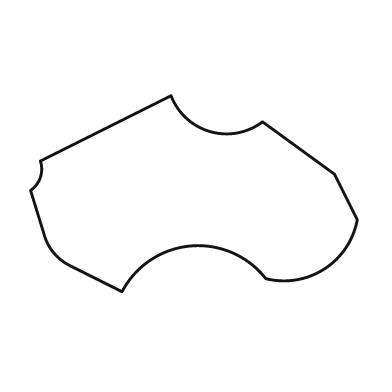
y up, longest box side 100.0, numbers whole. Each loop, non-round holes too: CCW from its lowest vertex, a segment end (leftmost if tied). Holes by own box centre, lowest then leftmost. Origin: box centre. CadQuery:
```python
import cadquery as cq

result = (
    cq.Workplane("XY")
    .moveTo(-22.0, -30.0)
    .threePointArc((-1.0, -16.0), (22.0, -26.0))
    .threePointArc((40.0, -23.0), (50.0, -8.0))
    .lineTo(43.0, 6.0)
    .lineTo(21.0, 22.0)
    .threePointArc((5.0, 19.0), (-7.0, 30.0))
    .lineTo(-47.0, 10.0)
    .threePointArc((-47.0, 5.0), (-50.0, 1.0))
    .lineTo(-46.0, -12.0)
    .threePointArc((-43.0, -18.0), (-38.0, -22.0))
    .close()
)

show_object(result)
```